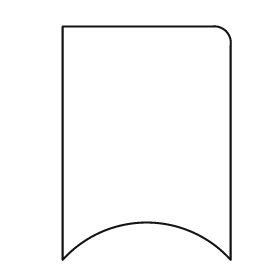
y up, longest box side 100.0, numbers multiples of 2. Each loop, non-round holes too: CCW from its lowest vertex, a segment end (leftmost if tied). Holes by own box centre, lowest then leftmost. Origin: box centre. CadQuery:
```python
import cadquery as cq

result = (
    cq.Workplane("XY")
    .moveTo(-36.0, -50.0)
    .threePointArc((0.0, -34.0), (36.0, -50.0))
    .lineTo(36.0, 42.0)
    .threePointArc((34.0, 48.0), (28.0, 50.0))
    .lineTo(-36.0, 50.0)
    .close()
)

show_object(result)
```